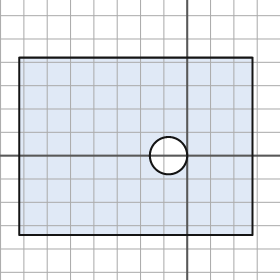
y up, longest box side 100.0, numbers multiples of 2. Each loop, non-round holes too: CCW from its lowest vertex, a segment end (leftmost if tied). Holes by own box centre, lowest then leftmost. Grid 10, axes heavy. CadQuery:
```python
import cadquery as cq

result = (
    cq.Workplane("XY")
    .moveTo(-72.0, -34.0)
    .lineTo(28.0, -34.0)
    .lineTo(28.0, 42.0)
    .lineTo(-72.0, 42.0)
    .close()
    .moveTo(-8.0, 0.0)
    .circle(8.0)
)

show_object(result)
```